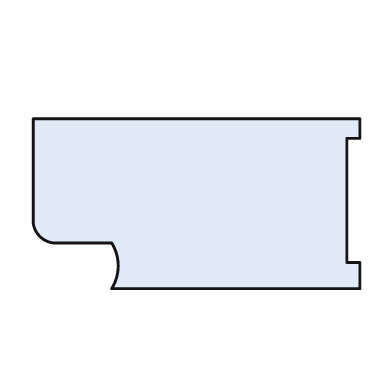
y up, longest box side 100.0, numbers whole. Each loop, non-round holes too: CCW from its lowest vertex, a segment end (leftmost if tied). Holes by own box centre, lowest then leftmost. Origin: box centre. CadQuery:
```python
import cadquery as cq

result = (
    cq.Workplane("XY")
    .moveTo(-26.0, -26.0)
    .lineTo(50.0, -26.0)
    .lineTo(50.0, -18.0)
    .lineTo(46.0, -18.0)
    .lineTo(46.0, 20.0)
    .lineTo(50.0, 20.0)
    .lineTo(50.0, 26.0)
    .lineTo(-50.0, 26.0)
    .lineTo(-50.0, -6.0)
    .threePointArc((-48.0, -10.0), (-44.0, -12.0))
    .lineTo(-26.0, -12.0)
    .threePointArc((-24.0, -19.0), (-26.0, -26.0))
    .close()
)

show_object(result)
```